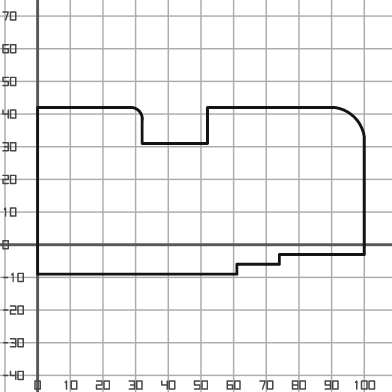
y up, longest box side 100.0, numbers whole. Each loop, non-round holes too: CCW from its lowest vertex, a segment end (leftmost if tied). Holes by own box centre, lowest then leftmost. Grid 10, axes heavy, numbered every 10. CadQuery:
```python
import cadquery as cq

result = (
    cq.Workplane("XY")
    .moveTo(0.0, -9.0)
    .lineTo(61.0, -9.0)
    .lineTo(61.0, -6.0)
    .lineTo(74.0, -6.0)
    .lineTo(74.0, -3.0)
    .lineTo(100.0, -3.0)
    .lineTo(100.0, 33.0)
    .threePointArc((97.0, 39.0), (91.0, 42.0))
    .lineTo(52.0, 42.0)
    .lineTo(52.0, 31.0)
    .lineTo(32.0, 31.0)
    .lineTo(32.0, 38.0)
    .threePointArc((31.0, 41.0), (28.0, 42.0))
    .lineTo(0.0, 42.0)
    .close()
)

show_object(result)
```